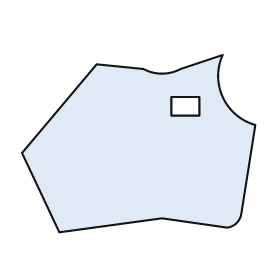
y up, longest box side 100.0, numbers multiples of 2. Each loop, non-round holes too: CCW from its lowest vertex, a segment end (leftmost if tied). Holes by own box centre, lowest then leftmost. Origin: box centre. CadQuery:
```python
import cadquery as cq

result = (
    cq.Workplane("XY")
    .moveTo(-34.0, -38.0)
    .lineTo(10.0, -32.0)
    .lineTo(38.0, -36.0)
    .threePointArc((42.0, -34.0), (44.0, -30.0))
    .lineTo(50.0, 8.0)
    .threePointArc((36.0, 20.0), (36.0, 38.0))
    .lineTo(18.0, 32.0)
    .threePointArc((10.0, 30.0), (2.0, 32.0))
    .lineTo(-18.0, 34.0)
    .lineTo(-50.0, -4.0)
    .close()
    .moveTo(14.0, 12.0)
    .lineTo(26.0, 12.0)
    .lineTo(26.0, 20.0)
    .lineTo(14.0, 20.0)
    .close()
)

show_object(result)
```